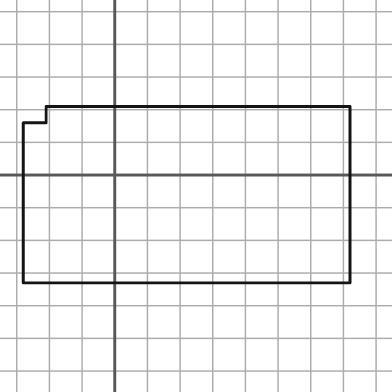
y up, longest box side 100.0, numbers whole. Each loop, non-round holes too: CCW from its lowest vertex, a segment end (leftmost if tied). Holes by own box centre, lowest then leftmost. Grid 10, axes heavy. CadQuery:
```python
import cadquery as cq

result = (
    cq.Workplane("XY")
    .moveTo(-28.0, -33.0)
    .lineTo(72.0, -33.0)
    .lineTo(72.0, 21.0)
    .lineTo(-21.0, 21.0)
    .lineTo(-21.0, 16.0)
    .lineTo(-28.0, 16.0)
    .close()
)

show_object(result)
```